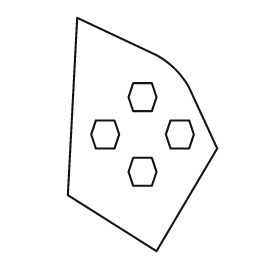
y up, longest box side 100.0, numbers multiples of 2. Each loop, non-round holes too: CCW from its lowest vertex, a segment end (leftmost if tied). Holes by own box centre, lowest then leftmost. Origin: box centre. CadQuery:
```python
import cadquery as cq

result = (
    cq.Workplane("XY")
    .moveTo(6.0, -50.0)
    .lineTo(32.0, -6.0)
    .lineTo(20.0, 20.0)
    .threePointArc((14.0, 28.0), (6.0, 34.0))
    .lineTo(-28.0, 50.0)
    .lineTo(-32.0, -26.0)
    .close()
    .moveTo(-4.0, -22.0)
    .lineTo(4.0, -22.0)
    .lineTo(6.0, -16.0)
    .lineTo(4.0, -10.0)
    .lineTo(-4.0, -10.0)
    .lineTo(-6.0, -16.0)
    .close()
    .moveTo(-20.0, -6.0)
    .lineTo(-12.0, -6.0)
    .lineTo(-10.0, 0.0)
    .lineTo(-12.0, 6.0)
    .lineTo(-20.0, 6.0)
    .lineTo(-22.0, 0.0)
    .close()
    .moveTo(12.0, -6.0)
    .lineTo(20.0, -6.0)
    .lineTo(22.0, 0.0)
    .lineTo(20.0, 6.0)
    .lineTo(12.0, 6.0)
    .lineTo(10.0, 0.0)
    .close()
    .moveTo(-4.0, 10.0)
    .lineTo(4.0, 10.0)
    .lineTo(6.0, 16.0)
    .lineTo(4.0, 22.0)
    .lineTo(-4.0, 22.0)
    .lineTo(-6.0, 16.0)
    .close()
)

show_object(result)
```